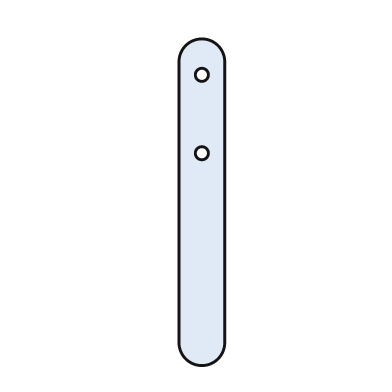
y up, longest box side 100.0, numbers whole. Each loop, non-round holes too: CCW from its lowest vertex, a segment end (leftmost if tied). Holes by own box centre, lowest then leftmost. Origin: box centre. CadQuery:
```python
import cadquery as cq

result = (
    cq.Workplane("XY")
    .moveTo(-7.0, -43.0)
    .threePointArc((0.0, -50.0), (7.0, -43.0))
    .lineTo(7.0, 43.0)
    .threePointArc((0.0, 50.0), (-7.0, 43.0))
    .close()
    .moveTo(0.0, 15.0)
    .circle(2.0)
    .moveTo(0.0, 39.0)
    .circle(2.0)
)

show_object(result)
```